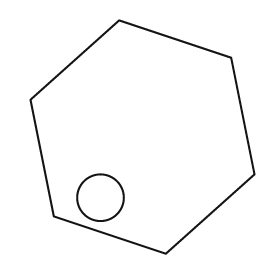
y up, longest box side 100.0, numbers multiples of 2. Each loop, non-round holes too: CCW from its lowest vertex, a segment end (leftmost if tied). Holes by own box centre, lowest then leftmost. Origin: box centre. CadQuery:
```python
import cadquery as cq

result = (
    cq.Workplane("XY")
    .moveTo(10.0, -50.0)
    .lineTo(48.0, -16.0)
    .lineTo(38.0, 34.0)
    .lineTo(-10.0, 50.0)
    .lineTo(-48.0, 16.0)
    .lineTo(-38.0, -34.0)
    .close()
    .moveTo(-18.0, -26.0)
    .circle(10.0)
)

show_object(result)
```